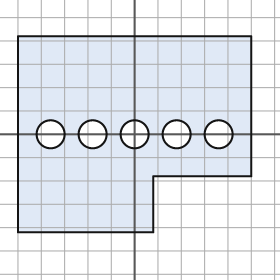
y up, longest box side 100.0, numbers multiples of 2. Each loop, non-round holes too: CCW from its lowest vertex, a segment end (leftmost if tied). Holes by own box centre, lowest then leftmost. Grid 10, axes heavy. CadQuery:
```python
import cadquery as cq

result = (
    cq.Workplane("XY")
    .moveTo(-50.0, -42.0)
    .lineTo(8.0, -42.0)
    .lineTo(8.0, -18.0)
    .lineTo(50.0, -18.0)
    .lineTo(50.0, 42.0)
    .lineTo(-50.0, 42.0)
    .close()
    .moveTo(-36.0, 0.0)
    .circle(6.0)
    .moveTo(-18.0, 0.0)
    .circle(6.0)
    .moveTo(0.0, 0.0)
    .circle(6.0)
    .moveTo(18.0, 0.0)
    .circle(6.0)
    .moveTo(36.0, 0.0)
    .circle(6.0)
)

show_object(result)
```